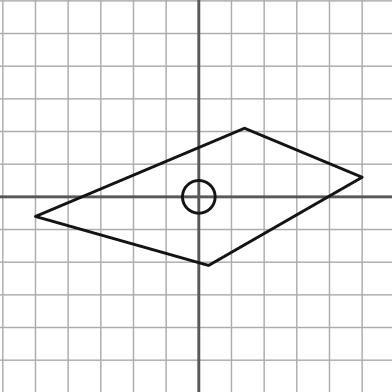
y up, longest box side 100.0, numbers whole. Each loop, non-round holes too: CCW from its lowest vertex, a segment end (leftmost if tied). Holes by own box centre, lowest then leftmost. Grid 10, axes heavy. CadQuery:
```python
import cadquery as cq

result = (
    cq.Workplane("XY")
    .moveTo(3.0, -21.0)
    .lineTo(50.0, 6.0)
    .lineTo(14.0, 21.0)
    .lineTo(-50.0, -6.0)
    .close()
    .moveTo(0.0, 0.0)
    .circle(5.0)
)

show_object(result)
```